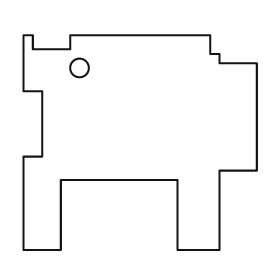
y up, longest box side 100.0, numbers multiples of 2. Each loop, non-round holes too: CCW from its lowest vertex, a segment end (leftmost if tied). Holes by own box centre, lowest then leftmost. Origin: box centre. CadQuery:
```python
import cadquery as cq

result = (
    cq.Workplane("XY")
    .moveTo(-50.0, -46.0)
    .lineTo(-34.0, -46.0)
    .lineTo(-34.0, -16.0)
    .lineTo(16.0, -16.0)
    .lineTo(16.0, -46.0)
    .lineTo(34.0, -46.0)
    .lineTo(34.0, -12.0)
    .lineTo(50.0, -12.0)
    .lineTo(50.0, 34.0)
    .lineTo(34.0, 34.0)
    .lineTo(34.0, 38.0)
    .lineTo(30.0, 38.0)
    .lineTo(30.0, 46.0)
    .lineTo(-30.0, 46.0)
    .lineTo(-30.0, 40.0)
    .lineTo(-46.0, 40.0)
    .lineTo(-46.0, 46.0)
    .lineTo(-50.0, 46.0)
    .lineTo(-50.0, 22.0)
    .lineTo(-42.0, 22.0)
    .lineTo(-42.0, -6.0)
    .lineTo(-50.0, -6.0)
    .close()
    .moveTo(-26.0, 32.0)
    .circle(4.0)
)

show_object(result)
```